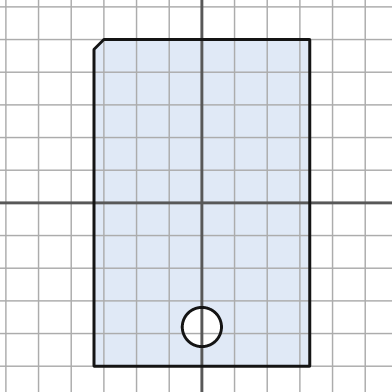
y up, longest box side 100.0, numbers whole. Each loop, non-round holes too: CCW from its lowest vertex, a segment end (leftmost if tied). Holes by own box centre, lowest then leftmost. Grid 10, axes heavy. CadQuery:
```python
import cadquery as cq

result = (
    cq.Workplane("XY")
    .moveTo(-33.0, -50.0)
    .lineTo(33.0, -50.0)
    .lineTo(33.0, 50.0)
    .lineTo(-30.0, 50.0)
    .lineTo(-33.0, 47.0)
    .close()
    .moveTo(0.0, -38.0)
    .circle(6.0)
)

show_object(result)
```